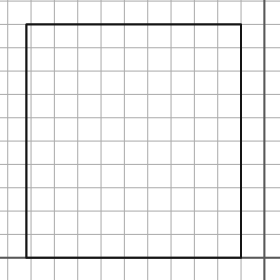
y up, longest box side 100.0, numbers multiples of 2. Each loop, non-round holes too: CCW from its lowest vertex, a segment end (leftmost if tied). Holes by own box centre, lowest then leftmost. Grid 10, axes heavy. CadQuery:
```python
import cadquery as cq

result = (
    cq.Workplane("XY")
    .moveTo(-102.0, 0.0)
    .lineTo(-10.0, 0.0)
    .lineTo(-10.0, 100.0)
    .lineTo(-102.0, 100.0)
    .close()
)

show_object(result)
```